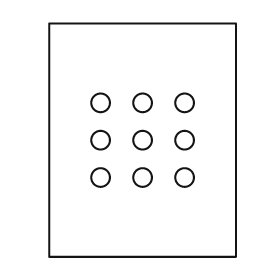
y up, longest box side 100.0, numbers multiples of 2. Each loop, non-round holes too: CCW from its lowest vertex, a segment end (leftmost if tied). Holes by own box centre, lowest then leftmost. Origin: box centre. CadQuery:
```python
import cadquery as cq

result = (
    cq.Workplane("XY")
    .moveTo(-40.0, -50.0)
    .lineTo(40.0, -50.0)
    .lineTo(40.0, 50.0)
    .lineTo(-40.0, 50.0)
    .close()
    .moveTo(-18.0, -16.0)
    .circle(4.0)
    .moveTo(0.0, -16.0)
    .circle(4.0)
    .moveTo(18.0, -16.0)
    .circle(4.0)
    .moveTo(-18.0, 0.0)
    .circle(4.0)
    .moveTo(0.0, 0.0)
    .circle(4.0)
    .moveTo(18.0, 0.0)
    .circle(4.0)
    .moveTo(-18.0, 16.0)
    .circle(4.0)
    .moveTo(0.0, 16.0)
    .circle(4.0)
    .moveTo(18.0, 16.0)
    .circle(4.0)
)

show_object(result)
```